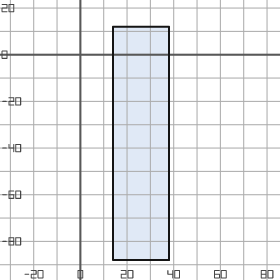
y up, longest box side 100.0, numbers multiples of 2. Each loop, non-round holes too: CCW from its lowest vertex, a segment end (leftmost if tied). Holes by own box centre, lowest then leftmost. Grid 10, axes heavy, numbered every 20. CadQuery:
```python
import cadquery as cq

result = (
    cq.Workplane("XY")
    .moveTo(14.0, -88.0)
    .lineTo(38.0, -88.0)
    .lineTo(38.0, 12.0)
    .lineTo(14.0, 12.0)
    .close()
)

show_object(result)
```